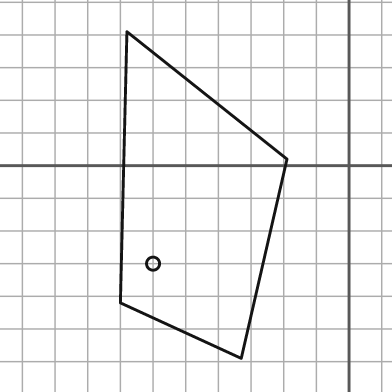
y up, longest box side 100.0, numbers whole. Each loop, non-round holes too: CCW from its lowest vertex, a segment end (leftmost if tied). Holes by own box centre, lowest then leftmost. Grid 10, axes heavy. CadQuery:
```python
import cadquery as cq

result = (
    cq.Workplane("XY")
    .moveTo(-33.0, -59.0)
    .lineTo(-19.0, 2.0)
    .lineTo(-68.0, 41.0)
    .lineTo(-70.0, -42.0)
    .close()
    .moveTo(-60.0, -30.0)
    .circle(2.0)
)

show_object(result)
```